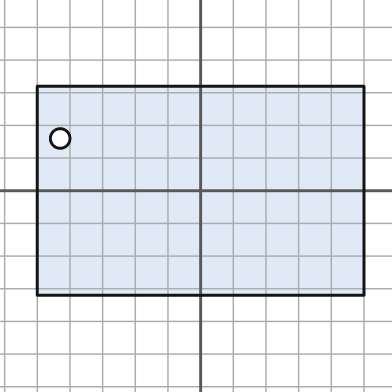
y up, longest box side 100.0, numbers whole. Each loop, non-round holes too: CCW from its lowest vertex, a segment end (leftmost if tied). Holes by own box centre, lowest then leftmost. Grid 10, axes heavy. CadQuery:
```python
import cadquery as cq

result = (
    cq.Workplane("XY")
    .moveTo(-50.0, -32.0)
    .lineTo(50.0, -32.0)
    .lineTo(50.0, 32.0)
    .lineTo(-50.0, 32.0)
    .close()
    .moveTo(-43.0, 16.0)
    .circle(3.0)
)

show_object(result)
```